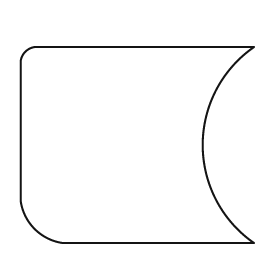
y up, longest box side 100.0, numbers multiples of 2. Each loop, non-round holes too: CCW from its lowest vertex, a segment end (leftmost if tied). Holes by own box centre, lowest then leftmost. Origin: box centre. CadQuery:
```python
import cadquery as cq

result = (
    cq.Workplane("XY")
    .moveTo(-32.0, -42.0)
    .lineTo(50.0, -42.0)
    .threePointArc((28.0, 0.0), (50.0, 42.0))
    .lineTo(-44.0, 42.0)
    .threePointArc((-48.0, 40.0), (-50.0, 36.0))
    .lineTo(-50.0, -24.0)
    .threePointArc((-44.0, -36.0), (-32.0, -42.0))
    .close()
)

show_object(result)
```